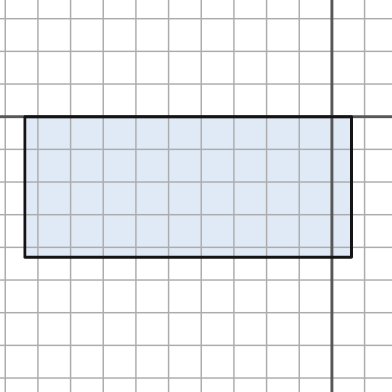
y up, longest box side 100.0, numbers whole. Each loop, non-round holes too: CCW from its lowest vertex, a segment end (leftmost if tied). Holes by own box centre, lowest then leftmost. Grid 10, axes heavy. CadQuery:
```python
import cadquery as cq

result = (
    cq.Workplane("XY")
    .moveTo(-94.0, -43.0)
    .lineTo(6.0, -43.0)
    .lineTo(6.0, 0.0)
    .lineTo(-94.0, 0.0)
    .close()
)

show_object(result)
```